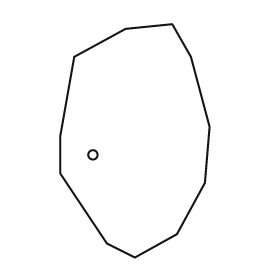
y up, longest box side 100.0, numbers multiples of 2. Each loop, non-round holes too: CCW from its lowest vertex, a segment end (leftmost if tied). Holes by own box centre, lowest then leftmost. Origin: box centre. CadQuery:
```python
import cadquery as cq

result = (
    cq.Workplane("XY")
    .moveTo(0.0, -50.0)
    .lineTo(18.0, -40.0)
    .lineTo(30.0, -18.0)
    .lineTo(32.0, 6.0)
    .lineTo(24.0, 36.0)
    .lineTo(16.0, 50.0)
    .lineTo(-4.0, 48.0)
    .lineTo(-26.0, 36.0)
    .lineTo(-32.0, 2.0)
    .lineTo(-32.0, -14.0)
    .lineTo(-12.0, -44.0)
    .close()
    .moveTo(-18.0, -6.0)
    .circle(2.0)
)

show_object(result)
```